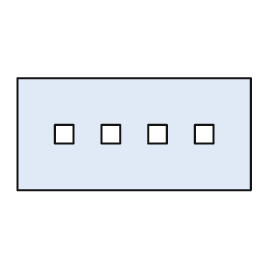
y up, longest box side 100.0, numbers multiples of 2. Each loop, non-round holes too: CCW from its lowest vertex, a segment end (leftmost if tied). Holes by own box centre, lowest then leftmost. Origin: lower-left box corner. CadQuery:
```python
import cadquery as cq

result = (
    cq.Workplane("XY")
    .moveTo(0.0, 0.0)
    .lineTo(100.0, 0.0)
    .lineTo(100.0, 48.0)
    .lineTo(0.0, 48.0)
    .close()
    .moveTo(16.0, 20.0)
    .lineTo(24.0, 20.0)
    .lineTo(24.0, 28.0)
    .lineTo(16.0, 28.0)
    .close()
    .moveTo(36.0, 20.0)
    .lineTo(44.0, 20.0)
    .lineTo(44.0, 28.0)
    .lineTo(36.0, 28.0)
    .close()
    .moveTo(56.0, 20.0)
    .lineTo(64.0, 20.0)
    .lineTo(64.0, 28.0)
    .lineTo(56.0, 28.0)
    .close()
    .moveTo(76.0, 20.0)
    .lineTo(84.0, 20.0)
    .lineTo(84.0, 28.0)
    .lineTo(76.0, 28.0)
    .close()
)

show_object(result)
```